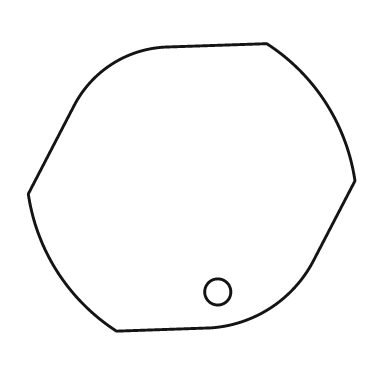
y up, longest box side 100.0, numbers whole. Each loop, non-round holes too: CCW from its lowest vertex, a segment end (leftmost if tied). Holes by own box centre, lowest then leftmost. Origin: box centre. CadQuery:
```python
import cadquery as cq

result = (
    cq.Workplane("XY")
    .moveTo(-23.0, -44.0)
    .lineTo(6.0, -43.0)
    .threePointArc((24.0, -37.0), (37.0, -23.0))
    .lineTo(50.0, 2.0)
    .threePointArc((41.0, 26.0), (23.0, 44.0))
    .lineTo(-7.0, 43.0)
    .threePointArc((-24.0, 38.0), (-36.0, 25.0))
    .lineTo(-50.0, -2.0)
    .threePointArc((-41.0, -26.0), (-23.0, -44.0))
    .close()
    .moveTo(8.0, -32.0)
    .circle(4.0)
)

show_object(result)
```